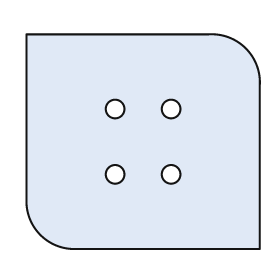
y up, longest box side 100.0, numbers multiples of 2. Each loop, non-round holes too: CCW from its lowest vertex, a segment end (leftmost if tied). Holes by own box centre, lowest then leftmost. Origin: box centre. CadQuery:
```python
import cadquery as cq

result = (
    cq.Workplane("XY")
    .moveTo(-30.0, -46.0)
    .lineTo(50.0, -46.0)
    .lineTo(50.0, 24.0)
    .threePointArc((44.0, 40.0), (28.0, 46.0))
    .lineTo(-50.0, 46.0)
    .lineTo(-50.0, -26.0)
    .threePointArc((-44.0, -40.0), (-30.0, -46.0))
    .close()
    .moveTo(-12.0, -14.0)
    .circle(4.0)
    .moveTo(12.0, -14.0)
    .circle(4.0)
    .moveTo(-12.0, 14.0)
    .circle(4.0)
    .moveTo(12.0, 14.0)
    .circle(4.0)
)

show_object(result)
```